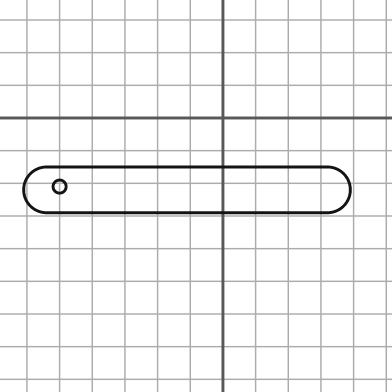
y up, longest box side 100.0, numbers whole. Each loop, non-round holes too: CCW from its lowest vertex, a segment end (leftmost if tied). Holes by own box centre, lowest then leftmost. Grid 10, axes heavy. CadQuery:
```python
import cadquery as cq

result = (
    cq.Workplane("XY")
    .moveTo(-54.0, -29.0)
    .lineTo(32.0, -29.0)
    .threePointArc((39.0, -22.0), (32.0, -15.0))
    .lineTo(-54.0, -15.0)
    .threePointArc((-61.0, -22.0), (-54.0, -29.0))
    .close()
    .moveTo(-50.0, -21.0)
    .circle(2.0)
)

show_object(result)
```